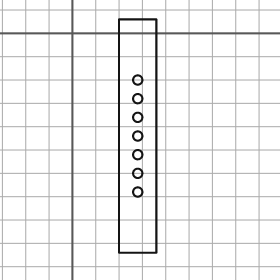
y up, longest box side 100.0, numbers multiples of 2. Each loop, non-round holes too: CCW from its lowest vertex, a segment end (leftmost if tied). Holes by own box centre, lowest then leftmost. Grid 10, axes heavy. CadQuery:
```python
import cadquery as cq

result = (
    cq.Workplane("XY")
    .moveTo(20.0, -94.0)
    .lineTo(36.0, -94.0)
    .lineTo(36.0, 6.0)
    .lineTo(20.0, 6.0)
    .close()
    .moveTo(28.0, -68.0)
    .circle(2.0)
    .moveTo(28.0, -60.0)
    .circle(2.0)
    .moveTo(28.0, -52.0)
    .circle(2.0)
    .moveTo(28.0, -44.0)
    .circle(2.0)
    .moveTo(28.0, -36.0)
    .circle(2.0)
    .moveTo(28.0, -28.0)
    .circle(2.0)
    .moveTo(28.0, -20.0)
    .circle(2.0)
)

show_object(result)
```